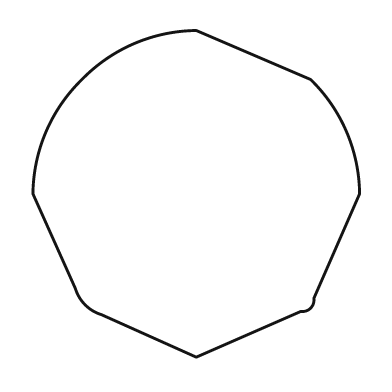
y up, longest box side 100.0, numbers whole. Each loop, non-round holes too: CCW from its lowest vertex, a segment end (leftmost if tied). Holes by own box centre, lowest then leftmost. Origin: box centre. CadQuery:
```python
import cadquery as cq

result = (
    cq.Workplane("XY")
    .moveTo(0.0, -50.0)
    .lineTo(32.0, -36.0)
    .threePointArc((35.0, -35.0), (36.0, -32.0))
    .lineTo(50.0, 0.0)
    .threePointArc((46.0, 19.0), (35.0, 35.0))
    .lineTo(0.0, 50.0)
    .threePointArc((-19.0, 46.0), (-35.0, 35.0))
    .threePointArc((-46.0, 19.0), (-50.0, 0.0))
    .lineTo(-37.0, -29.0)
    .threePointArc((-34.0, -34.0), (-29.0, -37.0))
    .close()
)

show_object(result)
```